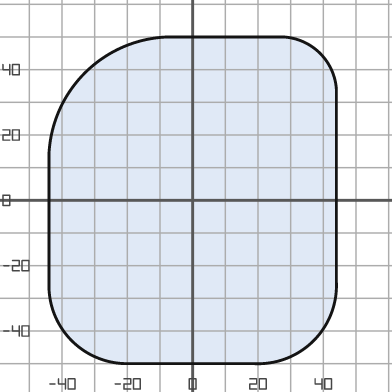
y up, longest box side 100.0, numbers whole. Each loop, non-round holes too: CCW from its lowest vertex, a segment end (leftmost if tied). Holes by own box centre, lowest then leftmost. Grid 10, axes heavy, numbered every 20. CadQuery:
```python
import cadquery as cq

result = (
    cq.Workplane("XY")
    .moveTo(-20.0, -50.0)
    .lineTo(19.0, -50.0)
    .threePointArc((37.0, -43.0), (44.0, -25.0))
    .lineTo(44.0, 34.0)
    .threePointArc((39.0, 45.0), (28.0, 50.0))
    .lineTo(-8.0, 50.0)
    .threePointArc((-33.0, 39.0), (-44.0, 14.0))
    .lineTo(-44.0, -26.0)
    .threePointArc((-37.0, -43.0), (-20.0, -50.0))
    .close()
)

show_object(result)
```